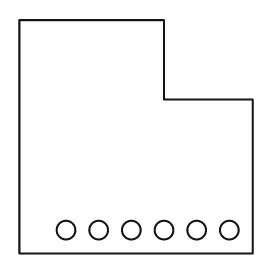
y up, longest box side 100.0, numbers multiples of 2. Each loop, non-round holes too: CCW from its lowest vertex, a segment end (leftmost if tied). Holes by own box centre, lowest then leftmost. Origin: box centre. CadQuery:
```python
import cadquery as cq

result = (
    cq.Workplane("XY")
    .moveTo(-50.0, -50.0)
    .lineTo(50.0, -50.0)
    .lineTo(50.0, 16.0)
    .lineTo(12.0, 16.0)
    .lineTo(12.0, 50.0)
    .lineTo(-50.0, 50.0)
    .close()
    .moveTo(-30.0, -40.0)
    .circle(4.0)
    .moveTo(-16.0, -40.0)
    .circle(4.0)
    .moveTo(-2.0, -40.0)
    .circle(4.0)
    .moveTo(12.0, -40.0)
    .circle(4.0)
    .moveTo(26.0, -40.0)
    .circle(4.0)
    .moveTo(40.0, -40.0)
    .circle(4.0)
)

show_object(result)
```